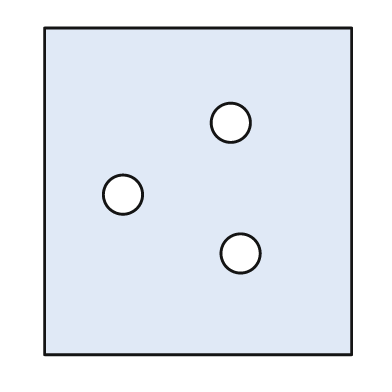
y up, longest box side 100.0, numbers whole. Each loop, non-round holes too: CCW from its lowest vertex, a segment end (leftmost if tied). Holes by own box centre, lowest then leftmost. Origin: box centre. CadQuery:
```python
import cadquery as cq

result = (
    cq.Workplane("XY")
    .moveTo(-47.0, -50.0)
    .lineTo(47.0, -50.0)
    .lineTo(47.0, 50.0)
    .lineTo(-47.0, 50.0)
    .close()
    .moveTo(13.0, -19.0)
    .circle(6.0)
    .moveTo(-23.0, -1.0)
    .circle(6.0)
    .moveTo(10.0, 21.0)
    .circle(6.0)
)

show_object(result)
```